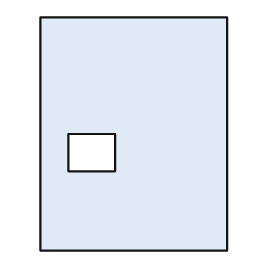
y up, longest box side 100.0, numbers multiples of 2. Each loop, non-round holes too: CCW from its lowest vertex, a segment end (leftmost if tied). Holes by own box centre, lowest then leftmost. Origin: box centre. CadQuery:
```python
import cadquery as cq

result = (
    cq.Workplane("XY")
    .moveTo(-40.0, -50.0)
    .lineTo(40.0, -50.0)
    .lineTo(40.0, 50.0)
    .lineTo(-40.0, 50.0)
    .close()
    .moveTo(-28.0, -16.0)
    .lineTo(-8.0, -16.0)
    .lineTo(-8.0, 0.0)
    .lineTo(-28.0, 0.0)
    .close()
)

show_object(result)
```